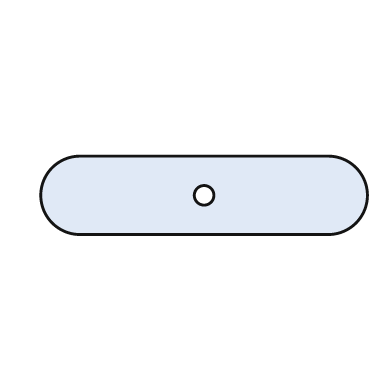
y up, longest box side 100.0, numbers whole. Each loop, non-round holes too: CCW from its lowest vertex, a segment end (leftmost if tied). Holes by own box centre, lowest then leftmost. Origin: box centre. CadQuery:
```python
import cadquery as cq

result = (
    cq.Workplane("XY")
    .moveTo(-38.0, -12.0)
    .lineTo(38.0, -12.0)
    .threePointArc((50.0, 0.0), (38.0, 12.0))
    .lineTo(-38.0, 12.0)
    .threePointArc((-50.0, 0.0), (-38.0, -12.0))
    .close()
    .moveTo(0.0, 0.0)
    .circle(3.0)
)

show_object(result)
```